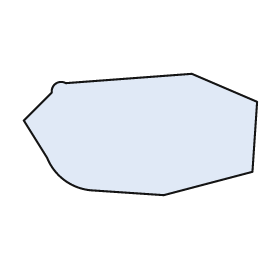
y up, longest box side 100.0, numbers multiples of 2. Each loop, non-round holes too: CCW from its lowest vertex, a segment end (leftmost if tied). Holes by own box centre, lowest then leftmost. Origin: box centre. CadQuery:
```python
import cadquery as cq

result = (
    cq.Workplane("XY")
    .moveTo(10.0, -26.0)
    .lineTo(48.0, -16.0)
    .lineTo(50.0, 14.0)
    .lineTo(22.0, 26.0)
    .lineTo(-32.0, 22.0)
    .threePointArc((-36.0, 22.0), (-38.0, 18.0))
    .lineTo(-50.0, 6.0)
    .lineTo(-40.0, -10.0)
    .threePointArc((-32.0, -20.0), (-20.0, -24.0))
    .close()
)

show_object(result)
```